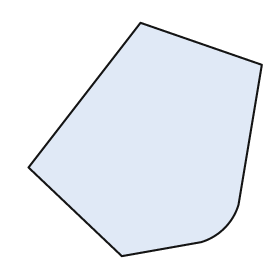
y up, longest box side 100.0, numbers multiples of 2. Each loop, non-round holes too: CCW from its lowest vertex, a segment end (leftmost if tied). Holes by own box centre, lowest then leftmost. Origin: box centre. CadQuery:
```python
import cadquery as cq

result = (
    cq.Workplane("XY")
    .moveTo(-10.0, -50.0)
    .lineTo(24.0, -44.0)
    .threePointArc((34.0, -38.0), (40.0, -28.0))
    .lineTo(50.0, 32.0)
    .lineTo(-2.0, 50.0)
    .lineTo(-50.0, -12.0)
    .close()
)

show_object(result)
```